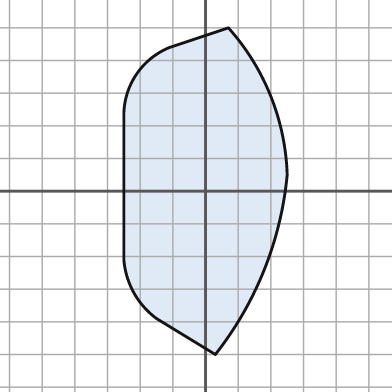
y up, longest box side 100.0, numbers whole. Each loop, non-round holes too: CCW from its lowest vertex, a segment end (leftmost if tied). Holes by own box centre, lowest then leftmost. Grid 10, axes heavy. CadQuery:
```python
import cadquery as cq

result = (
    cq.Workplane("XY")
    .moveTo(3.0, -50.0)
    .threePointArc((18.0, -24.0), (25.0, 5.0))
    .threePointArc((20.0, 29.0), (7.0, 50.0))
    .lineTo(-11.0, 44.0)
    .threePointArc((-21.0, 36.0), (-25.0, 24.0))
    .lineTo(-25.0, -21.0)
    .threePointArc((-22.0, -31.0), (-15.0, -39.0))
    .close()
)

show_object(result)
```